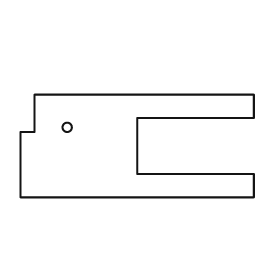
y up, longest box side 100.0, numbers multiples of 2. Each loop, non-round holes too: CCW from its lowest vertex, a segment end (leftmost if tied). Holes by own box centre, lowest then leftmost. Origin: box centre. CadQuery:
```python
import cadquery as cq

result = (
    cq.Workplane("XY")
    .moveTo(-50.0, -22.0)
    .lineTo(50.0, -22.0)
    .lineTo(50.0, -12.0)
    .lineTo(0.0, -12.0)
    .lineTo(0.0, 12.0)
    .lineTo(50.0, 12.0)
    .lineTo(50.0, 22.0)
    .lineTo(-44.0, 22.0)
    .lineTo(-44.0, 6.0)
    .lineTo(-50.0, 6.0)
    .close()
    .moveTo(-30.0, 8.0)
    .circle(2.0)
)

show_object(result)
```